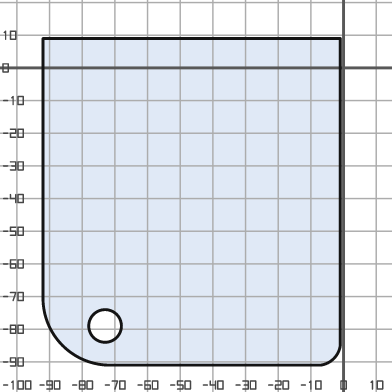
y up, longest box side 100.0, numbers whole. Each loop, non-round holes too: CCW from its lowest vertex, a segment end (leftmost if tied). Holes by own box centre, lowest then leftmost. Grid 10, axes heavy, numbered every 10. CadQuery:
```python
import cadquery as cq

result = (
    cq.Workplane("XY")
    .moveTo(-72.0, -91.0)
    .lineTo(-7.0, -91.0)
    .threePointArc((-3.0, -89.0), (-1.0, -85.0))
    .lineTo(-1.0, 9.0)
    .lineTo(-92.0, 9.0)
    .lineTo(-92.0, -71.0)
    .threePointArc((-86.0, -85.0), (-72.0, -91.0))
    .close()
    .moveTo(-73.0, -79.0)
    .circle(5.0)
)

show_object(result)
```